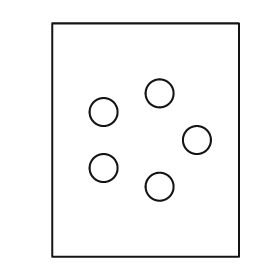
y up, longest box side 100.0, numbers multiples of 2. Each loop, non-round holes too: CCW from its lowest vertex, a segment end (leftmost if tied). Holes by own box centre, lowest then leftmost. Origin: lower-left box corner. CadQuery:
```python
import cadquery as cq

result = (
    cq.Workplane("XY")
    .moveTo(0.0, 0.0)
    .lineTo(80.0, 0.0)
    .lineTo(80.0, 100.0)
    .lineTo(0.0, 100.0)
    .close()
    .moveTo(46.0, 30.0)
    .circle(6.0)
    .moveTo(22.0, 38.0)
    .circle(6.0)
    .moveTo(62.0, 50.0)
    .circle(6.0)
    .moveTo(22.0, 62.0)
    .circle(6.0)
    .moveTo(46.0, 70.0)
    .circle(6.0)
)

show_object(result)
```